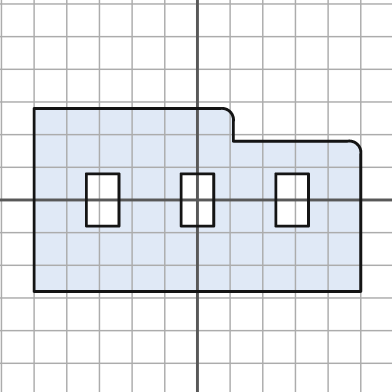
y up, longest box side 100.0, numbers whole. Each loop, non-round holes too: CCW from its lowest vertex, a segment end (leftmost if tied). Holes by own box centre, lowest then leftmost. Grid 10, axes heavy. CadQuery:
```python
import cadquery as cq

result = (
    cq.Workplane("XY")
    .moveTo(-50.0, -28.0)
    .lineTo(50.0, -28.0)
    .lineTo(50.0, 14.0)
    .threePointArc((49.0, 17.0), (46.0, 18.0))
    .lineTo(11.0, 18.0)
    .lineTo(11.0, 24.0)
    .threePointArc((10.0, 27.0), (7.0, 28.0))
    .lineTo(-50.0, 28.0)
    .close()
    .moveTo(-34.0, -8.0)
    .lineTo(-24.0, -8.0)
    .lineTo(-24.0, 8.0)
    .lineTo(-34.0, 8.0)
    .close()
    .moveTo(-5.0, -8.0)
    .lineTo(5.0, -8.0)
    .lineTo(5.0, 8.0)
    .lineTo(-5.0, 8.0)
    .close()
    .moveTo(24.0, -8.0)
    .lineTo(34.0, -8.0)
    .lineTo(34.0, 8.0)
    .lineTo(24.0, 8.0)
    .close()
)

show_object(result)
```